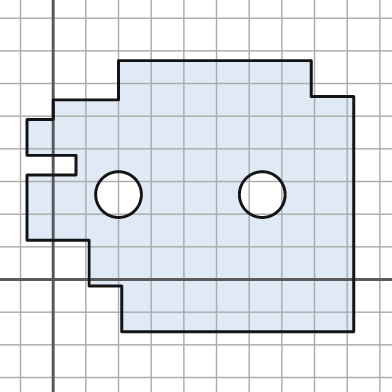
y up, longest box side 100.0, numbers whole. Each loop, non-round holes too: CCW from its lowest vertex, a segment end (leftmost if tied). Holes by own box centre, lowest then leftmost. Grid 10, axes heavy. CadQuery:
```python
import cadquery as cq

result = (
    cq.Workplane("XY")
    .moveTo(21.0, -16.0)
    .lineTo(92.0, -16.0)
    .lineTo(92.0, 56.0)
    .lineTo(79.0, 56.0)
    .lineTo(79.0, 67.0)
    .lineTo(20.0, 67.0)
    .lineTo(20.0, 55.0)
    .lineTo(0.0, 55.0)
    .lineTo(0.0, 49.0)
    .lineTo(-8.0, 49.0)
    .lineTo(-8.0, 38.0)
    .lineTo(7.0, 38.0)
    .lineTo(7.0, 32.0)
    .lineTo(-8.0, 32.0)
    .lineTo(-8.0, 12.0)
    .lineTo(11.0, 12.0)
    .lineTo(11.0, -2.0)
    .lineTo(21.0, -2.0)
    .close()
    .moveTo(20.0, 26.0)
    .circle(7.0)
    .moveTo(64.0, 26.0)
    .circle(7.0)
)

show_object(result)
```